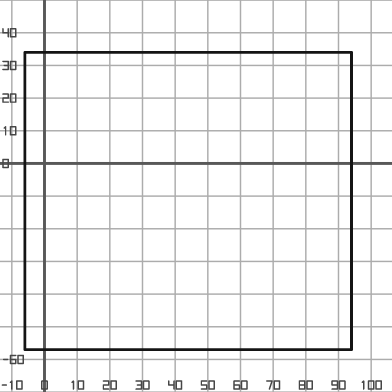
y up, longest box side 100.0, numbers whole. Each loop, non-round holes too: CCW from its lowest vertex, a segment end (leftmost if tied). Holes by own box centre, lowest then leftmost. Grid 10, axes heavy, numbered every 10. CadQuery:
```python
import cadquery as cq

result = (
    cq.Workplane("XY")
    .moveTo(-6.0, -57.0)
    .lineTo(94.0, -57.0)
    .lineTo(94.0, 34.0)
    .lineTo(-6.0, 34.0)
    .close()
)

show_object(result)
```